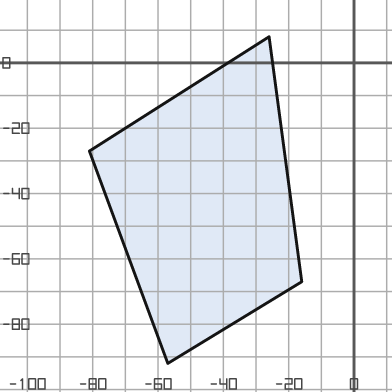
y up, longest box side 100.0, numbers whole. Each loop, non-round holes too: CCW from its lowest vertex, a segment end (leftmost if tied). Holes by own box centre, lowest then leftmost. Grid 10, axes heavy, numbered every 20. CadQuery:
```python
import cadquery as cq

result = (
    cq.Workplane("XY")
    .moveTo(-57.0, -92.0)
    .lineTo(-16.0, -67.0)
    .lineTo(-26.0, 8.0)
    .lineTo(-81.0, -27.0)
    .close()
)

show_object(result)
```